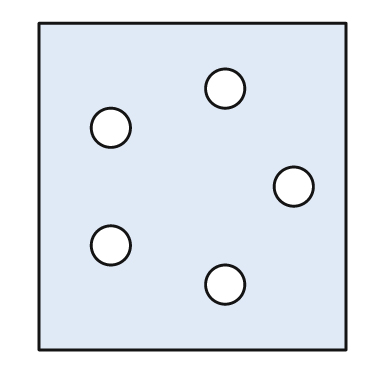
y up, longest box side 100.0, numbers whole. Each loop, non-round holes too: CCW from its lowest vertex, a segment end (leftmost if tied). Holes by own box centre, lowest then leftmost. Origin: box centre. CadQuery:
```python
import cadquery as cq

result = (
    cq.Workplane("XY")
    .moveTo(-47.0, -50.0)
    .lineTo(47.0, -50.0)
    .lineTo(47.0, 50.0)
    .lineTo(-47.0, 50.0)
    .close()
    .moveTo(10.0, -30.0)
    .circle(6.0)
    .moveTo(-25.0, -18.0)
    .circle(6.0)
    .moveTo(31.0, 0.0)
    .circle(6.0)
    .moveTo(-25.0, 18.0)
    .circle(6.0)
    .moveTo(10.0, 30.0)
    .circle(6.0)
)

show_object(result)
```